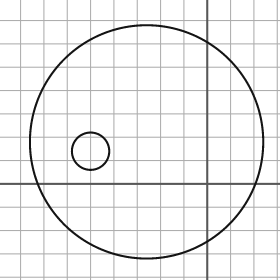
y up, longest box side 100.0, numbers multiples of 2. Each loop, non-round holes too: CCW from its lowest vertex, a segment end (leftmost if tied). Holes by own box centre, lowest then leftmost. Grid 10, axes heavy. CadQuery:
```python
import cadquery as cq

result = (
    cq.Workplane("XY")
    .moveTo(-26.0, 18.0)
    .circle(50.0)
    .moveTo(-50.0, 14.0)
    .circle(8.0)
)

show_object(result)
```